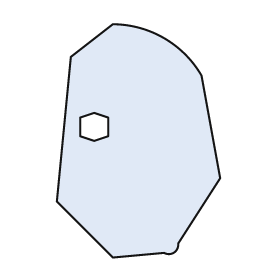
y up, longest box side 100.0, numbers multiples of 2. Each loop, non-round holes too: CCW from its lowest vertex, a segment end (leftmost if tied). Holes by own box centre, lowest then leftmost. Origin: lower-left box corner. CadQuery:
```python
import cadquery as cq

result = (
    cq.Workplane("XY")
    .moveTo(24.0, 0.0)
    .lineTo(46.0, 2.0)
    .threePointArc((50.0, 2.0), (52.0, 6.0))
    .lineTo(70.0, 34.0)
    .lineTo(62.0, 78.0)
    .threePointArc((46.0, 94.0), (24.0, 100.0))
    .lineTo(6.0, 86.0)
    .lineTo(0.0, 24.0)
    .close()
    .moveTo(16.0, 50.0)
    .lineTo(22.0, 52.0)
    .lineTo(22.0, 60.0)
    .lineTo(16.0, 62.0)
    .lineTo(10.0, 60.0)
    .lineTo(10.0, 52.0)
    .close()
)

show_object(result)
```